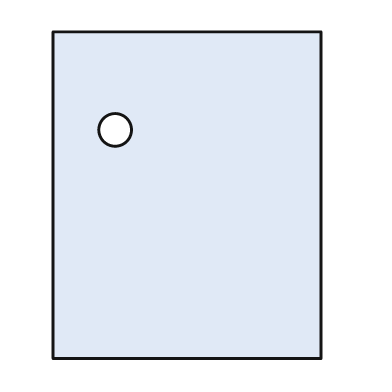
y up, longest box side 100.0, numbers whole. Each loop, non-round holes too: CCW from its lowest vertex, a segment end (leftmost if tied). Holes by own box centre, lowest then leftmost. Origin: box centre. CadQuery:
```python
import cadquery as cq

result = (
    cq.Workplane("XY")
    .moveTo(-41.0, -50.0)
    .lineTo(41.0, -50.0)
    .lineTo(41.0, 50.0)
    .lineTo(-41.0, 50.0)
    .close()
    .moveTo(-22.0, 20.0)
    .circle(5.0)
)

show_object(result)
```